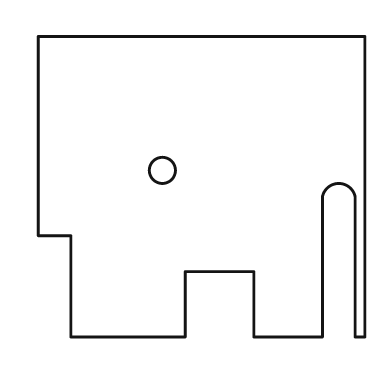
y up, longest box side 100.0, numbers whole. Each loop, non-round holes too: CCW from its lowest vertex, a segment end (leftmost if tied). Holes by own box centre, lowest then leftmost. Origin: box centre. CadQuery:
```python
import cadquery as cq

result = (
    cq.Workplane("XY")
    .moveTo(-40.0, -46.0)
    .lineTo(-5.0, -46.0)
    .lineTo(-5.0, -26.0)
    .lineTo(16.0, -26.0)
    .lineTo(16.0, -46.0)
    .lineTo(37.0, -46.0)
    .lineTo(37.0, -3.0)
    .threePointArc((42.0, 1.0), (47.0, -3.0))
    .lineTo(47.0, -46.0)
    .lineTo(50.0, -46.0)
    .lineTo(50.0, 46.0)
    .lineTo(-50.0, 46.0)
    .lineTo(-50.0, -15.0)
    .lineTo(-40.0, -15.0)
    .close()
    .moveTo(-12.0, 5.0)
    .circle(4.0)
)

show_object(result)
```